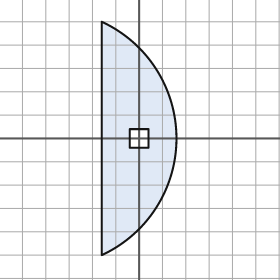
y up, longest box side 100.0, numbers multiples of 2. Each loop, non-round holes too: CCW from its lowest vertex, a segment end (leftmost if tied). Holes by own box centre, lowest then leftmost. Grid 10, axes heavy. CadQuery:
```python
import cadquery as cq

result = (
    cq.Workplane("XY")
    .moveTo(-16.0, -50.0)
    .threePointArc((16.0, 0.0), (-16.0, 50.0))
    .close()
    .moveTo(-4.0, -4.0)
    .lineTo(4.0, -4.0)
    .lineTo(4.0, 4.0)
    .lineTo(-4.0, 4.0)
    .close()
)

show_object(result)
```